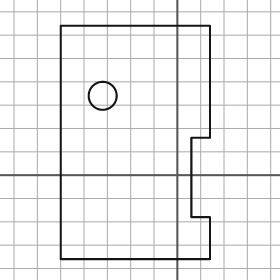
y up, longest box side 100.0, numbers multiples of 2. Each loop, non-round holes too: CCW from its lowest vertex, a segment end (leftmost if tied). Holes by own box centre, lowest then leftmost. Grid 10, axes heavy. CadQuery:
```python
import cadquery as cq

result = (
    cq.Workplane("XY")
    .moveTo(-50.0, -36.0)
    .lineTo(14.0, -36.0)
    .lineTo(14.0, -18.0)
    .lineTo(6.0, -18.0)
    .lineTo(6.0, 16.0)
    .lineTo(14.0, 16.0)
    .lineTo(14.0, 64.0)
    .lineTo(-50.0, 64.0)
    .close()
    .moveTo(-32.0, 34.0)
    .circle(6.0)
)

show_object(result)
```